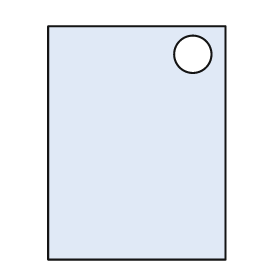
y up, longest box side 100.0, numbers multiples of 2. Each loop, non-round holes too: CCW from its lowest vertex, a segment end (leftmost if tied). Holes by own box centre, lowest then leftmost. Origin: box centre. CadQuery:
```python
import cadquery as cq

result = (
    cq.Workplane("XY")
    .moveTo(-38.0, -50.0)
    .lineTo(38.0, -50.0)
    .lineTo(38.0, 50.0)
    .lineTo(-38.0, 50.0)
    .close()
    .moveTo(24.0, 38.0)
    .circle(8.0)
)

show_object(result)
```